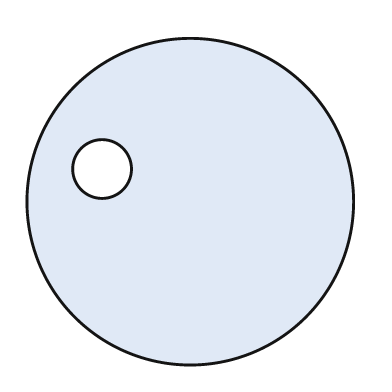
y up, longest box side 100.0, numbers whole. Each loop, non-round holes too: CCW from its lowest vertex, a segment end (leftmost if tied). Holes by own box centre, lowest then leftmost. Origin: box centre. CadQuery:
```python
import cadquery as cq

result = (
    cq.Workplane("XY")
    .moveTo(0.0, 0.0)
    .circle(50.0)
    .moveTo(-27.0, 10.0)
    .circle(9.0)
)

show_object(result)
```